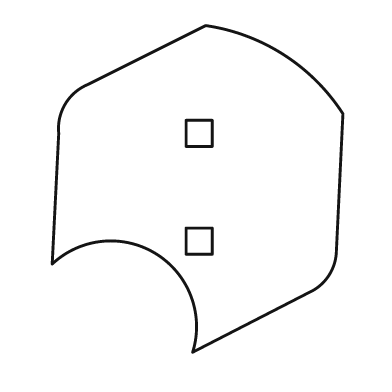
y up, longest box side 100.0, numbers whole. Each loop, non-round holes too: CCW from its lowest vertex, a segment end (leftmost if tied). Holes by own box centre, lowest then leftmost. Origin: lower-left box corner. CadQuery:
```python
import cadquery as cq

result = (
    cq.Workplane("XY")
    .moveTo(43.0, 0.0)
    .lineTo(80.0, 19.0)
    .threePointArc((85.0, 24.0), (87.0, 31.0))
    .lineTo(89.0, 73.0)
    .threePointArc((71.0, 91.0), (47.0, 100.0))
    .lineTo(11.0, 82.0)
    .threePointArc((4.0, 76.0), (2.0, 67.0))
    .lineTo(0.0, 27.0)
    .threePointArc((32.0, 30.0), (43.0, 0.0))
    .close()
    .moveTo(41.0, 30.0)
    .lineTo(49.0, 30.0)
    .lineTo(49.0, 38.0)
    .lineTo(41.0, 38.0)
    .close()
    .moveTo(41.0, 63.0)
    .lineTo(49.0, 63.0)
    .lineTo(49.0, 71.0)
    .lineTo(41.0, 71.0)
    .close()
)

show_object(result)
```